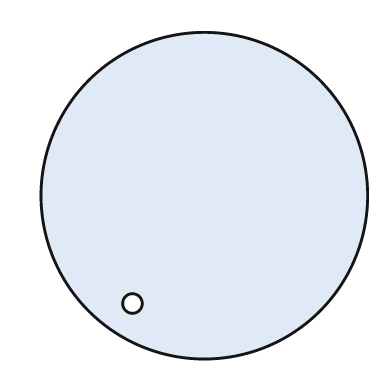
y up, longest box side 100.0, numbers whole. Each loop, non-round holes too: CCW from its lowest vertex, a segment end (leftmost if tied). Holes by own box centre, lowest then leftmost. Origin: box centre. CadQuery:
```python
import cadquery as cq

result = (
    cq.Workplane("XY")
    .moveTo(0.0, 0.0)
    .circle(50.0)
    .moveTo(-22.0, -33.0)
    .circle(3.0)
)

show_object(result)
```